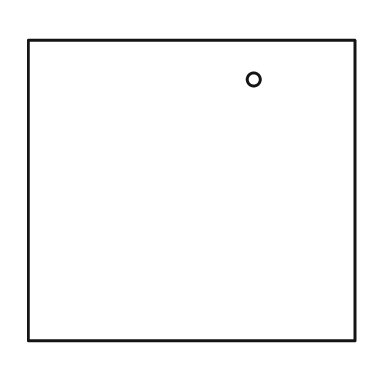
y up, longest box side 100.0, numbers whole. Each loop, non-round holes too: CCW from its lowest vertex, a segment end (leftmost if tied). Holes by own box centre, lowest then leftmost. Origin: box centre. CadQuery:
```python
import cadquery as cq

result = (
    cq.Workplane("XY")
    .moveTo(-50.0, -46.0)
    .lineTo(50.0, -46.0)
    .lineTo(50.0, 46.0)
    .lineTo(-50.0, 46.0)
    .close()
    .moveTo(19.0, 34.0)
    .circle(2.0)
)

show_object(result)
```